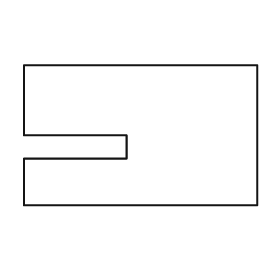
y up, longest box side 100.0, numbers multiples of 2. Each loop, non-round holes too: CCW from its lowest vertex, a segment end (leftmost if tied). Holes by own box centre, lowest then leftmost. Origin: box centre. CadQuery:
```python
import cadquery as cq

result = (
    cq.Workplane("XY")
    .moveTo(-50.0, -30.0)
    .lineTo(50.0, -30.0)
    .lineTo(50.0, 30.0)
    .lineTo(-50.0, 30.0)
    .lineTo(-50.0, 0.0)
    .lineTo(-6.0, 0.0)
    .lineTo(-6.0, -10.0)
    .lineTo(-50.0, -10.0)
    .close()
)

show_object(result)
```